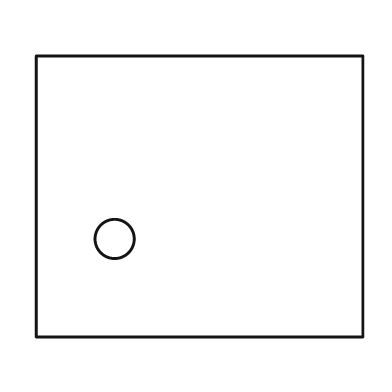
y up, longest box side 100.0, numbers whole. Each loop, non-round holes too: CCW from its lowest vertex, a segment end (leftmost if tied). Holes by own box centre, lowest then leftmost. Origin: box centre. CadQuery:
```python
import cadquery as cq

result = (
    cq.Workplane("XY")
    .moveTo(-50.0, -43.0)
    .lineTo(50.0, -43.0)
    .lineTo(50.0, 43.0)
    .lineTo(-50.0, 43.0)
    .close()
    .moveTo(-26.0, -13.0)
    .circle(6.0)
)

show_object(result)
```